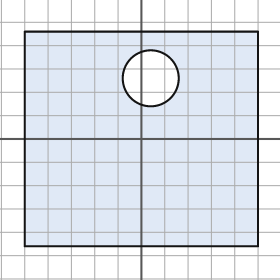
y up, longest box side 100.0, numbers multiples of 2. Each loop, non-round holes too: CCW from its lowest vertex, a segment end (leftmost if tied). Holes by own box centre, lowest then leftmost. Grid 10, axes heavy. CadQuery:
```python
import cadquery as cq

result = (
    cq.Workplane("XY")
    .moveTo(-50.0, -46.0)
    .lineTo(50.0, -46.0)
    .lineTo(50.0, 46.0)
    .lineTo(-50.0, 46.0)
    .close()
    .moveTo(4.0, 26.0)
    .circle(12.0)
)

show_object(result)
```